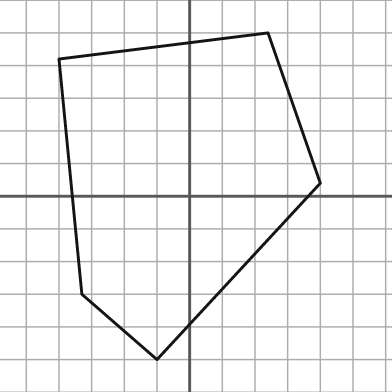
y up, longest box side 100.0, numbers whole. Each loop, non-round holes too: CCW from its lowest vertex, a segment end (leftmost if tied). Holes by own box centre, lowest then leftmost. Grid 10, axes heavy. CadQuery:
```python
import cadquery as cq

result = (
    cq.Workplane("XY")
    .moveTo(-10.0, -50.0)
    .lineTo(40.0, 4.0)
    .lineTo(24.0, 50.0)
    .lineTo(-40.0, 42.0)
    .lineTo(-33.0, -30.0)
    .close()
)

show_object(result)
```